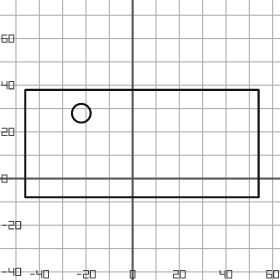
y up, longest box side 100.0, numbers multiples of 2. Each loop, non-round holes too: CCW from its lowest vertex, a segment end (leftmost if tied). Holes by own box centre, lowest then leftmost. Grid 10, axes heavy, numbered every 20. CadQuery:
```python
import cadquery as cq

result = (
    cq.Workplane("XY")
    .moveTo(-46.0, -8.0)
    .lineTo(54.0, -8.0)
    .lineTo(54.0, 38.0)
    .lineTo(-46.0, 38.0)
    .close()
    .moveTo(-22.0, 28.0)
    .circle(4.0)
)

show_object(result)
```